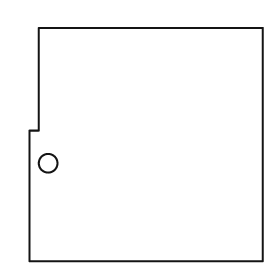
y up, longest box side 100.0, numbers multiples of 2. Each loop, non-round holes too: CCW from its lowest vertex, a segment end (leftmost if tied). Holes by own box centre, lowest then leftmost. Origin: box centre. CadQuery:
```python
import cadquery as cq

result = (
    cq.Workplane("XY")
    .moveTo(-50.0, -50.0)
    .lineTo(50.0, -50.0)
    .lineTo(50.0, 50.0)
    .lineTo(-46.0, 50.0)
    .lineTo(-46.0, 6.0)
    .lineTo(-50.0, 6.0)
    .close()
    .moveTo(-42.0, -8.0)
    .circle(4.0)
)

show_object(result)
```